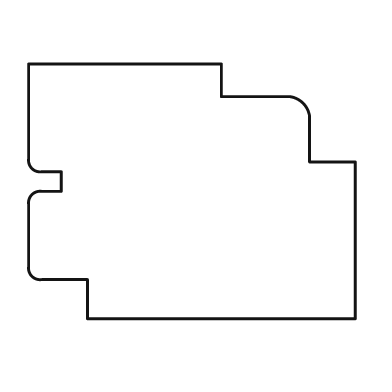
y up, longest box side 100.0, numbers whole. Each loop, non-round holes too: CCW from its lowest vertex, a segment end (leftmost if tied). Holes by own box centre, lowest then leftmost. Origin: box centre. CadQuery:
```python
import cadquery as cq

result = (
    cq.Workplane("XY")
    .moveTo(-32.0, -39.0)
    .lineTo(50.0, -39.0)
    .lineTo(50.0, 9.0)
    .lineTo(36.0, 9.0)
    .lineTo(36.0, 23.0)
    .threePointArc((34.0, 27.0), (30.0, 29.0))
    .lineTo(9.0, 29.0)
    .lineTo(9.0, 39.0)
    .lineTo(-50.0, 39.0)
    .lineTo(-50.0, 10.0)
    .threePointArc((-49.0, 7.0), (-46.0, 6.0))
    .lineTo(-40.0, 6.0)
    .lineTo(-40.0, 0.0)
    .lineTo(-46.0, 0.0)
    .threePointArc((-49.0, -1.0), (-50.0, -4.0))
    .lineTo(-50.0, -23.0)
    .threePointArc((-49.0, -26.0), (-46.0, -27.0))
    .lineTo(-32.0, -27.0)
    .close()
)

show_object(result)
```